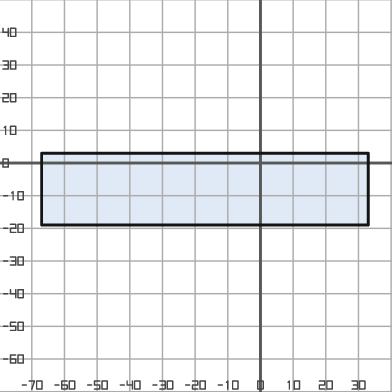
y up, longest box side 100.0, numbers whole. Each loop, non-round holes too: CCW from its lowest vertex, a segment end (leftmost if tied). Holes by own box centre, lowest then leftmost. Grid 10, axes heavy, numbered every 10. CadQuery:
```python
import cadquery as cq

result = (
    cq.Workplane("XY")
    .moveTo(-67.0, -19.0)
    .lineTo(33.0, -19.0)
    .lineTo(33.0, 3.0)
    .lineTo(-67.0, 3.0)
    .close()
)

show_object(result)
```